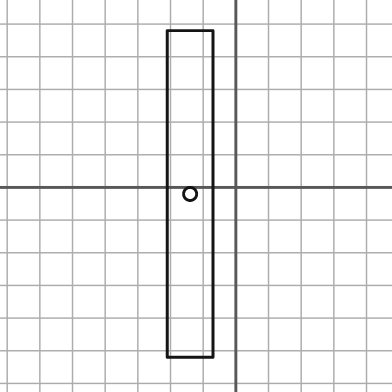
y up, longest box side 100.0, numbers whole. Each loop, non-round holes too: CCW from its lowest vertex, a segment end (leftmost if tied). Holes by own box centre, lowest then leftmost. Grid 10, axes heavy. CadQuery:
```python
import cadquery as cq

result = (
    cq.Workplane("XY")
    .moveTo(-21.0, -52.0)
    .lineTo(-7.0, -52.0)
    .lineTo(-7.0, 48.0)
    .lineTo(-21.0, 48.0)
    .close()
    .moveTo(-14.0, -2.0)
    .circle(2.0)
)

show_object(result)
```